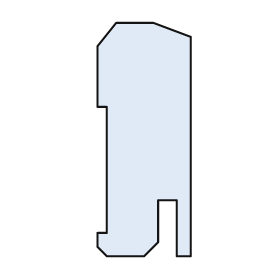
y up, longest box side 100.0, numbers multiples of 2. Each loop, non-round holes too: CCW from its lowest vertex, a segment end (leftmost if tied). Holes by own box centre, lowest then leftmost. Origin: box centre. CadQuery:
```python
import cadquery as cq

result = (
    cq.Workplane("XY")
    .moveTo(-16.0, -50.0)
    .lineTo(0.0, -50.0)
    .lineTo(6.0, -44.0)
    .lineTo(6.0, -26.0)
    .lineTo(14.0, -26.0)
    .lineTo(14.0, -50.0)
    .lineTo(20.0, -50.0)
    .lineTo(20.0, 44.0)
    .lineTo(4.0, 50.0)
    .lineTo(-12.0, 50.0)
    .lineTo(-20.0, 40.0)
    .lineTo(-20.0, 14.0)
    .lineTo(-16.0, 14.0)
    .lineTo(-16.0, -40.0)
    .lineTo(-20.0, -40.0)
    .lineTo(-20.0, -46.0)
    .close()
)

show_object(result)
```